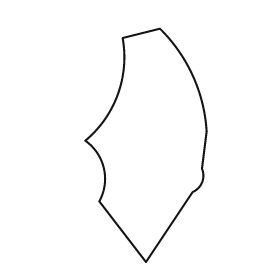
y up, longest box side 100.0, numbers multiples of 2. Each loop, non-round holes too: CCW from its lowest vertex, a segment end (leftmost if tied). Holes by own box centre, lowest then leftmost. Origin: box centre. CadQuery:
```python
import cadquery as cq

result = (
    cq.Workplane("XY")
    .moveTo(0.0, -50.0)
    .lineTo(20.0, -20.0)
    .threePointArc((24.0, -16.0), (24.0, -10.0))
    .lineTo(26.0, 6.0)
    .threePointArc((20.0, 30.0), (6.0, 50.0))
    .lineTo(-10.0, 46.0)
    .threePointArc((-12.0, 22.0), (-26.0, 2.0))
    .threePointArc((-18.0, -10.0), (-20.0, -24.0))
    .close()
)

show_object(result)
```